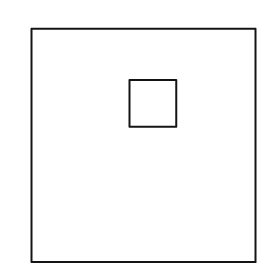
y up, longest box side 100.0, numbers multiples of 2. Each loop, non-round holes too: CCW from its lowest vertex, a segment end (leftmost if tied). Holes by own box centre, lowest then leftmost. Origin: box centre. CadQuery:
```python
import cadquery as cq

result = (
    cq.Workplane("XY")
    .moveTo(-48.0, -50.0)
    .lineTo(48.0, -50.0)
    .lineTo(48.0, 50.0)
    .lineTo(-48.0, 50.0)
    .close()
    .moveTo(-6.0, 8.0)
    .lineTo(14.0, 8.0)
    .lineTo(14.0, 28.0)
    .lineTo(-6.0, 28.0)
    .close()
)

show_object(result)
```